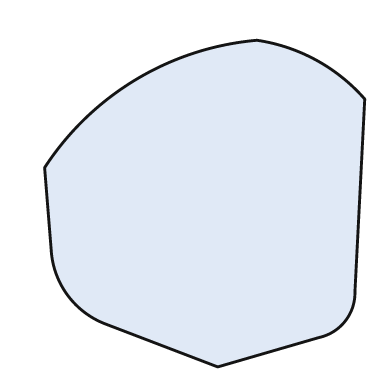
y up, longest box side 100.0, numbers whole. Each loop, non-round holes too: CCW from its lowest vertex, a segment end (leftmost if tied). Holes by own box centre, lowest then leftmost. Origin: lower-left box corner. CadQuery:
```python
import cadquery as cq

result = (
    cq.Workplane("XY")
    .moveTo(53.0, 0.0)
    .lineTo(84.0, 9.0)
    .threePointArc((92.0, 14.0), (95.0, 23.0))
    .lineTo(98.0, 82.0)
    .threePointArc((83.0, 94.0), (65.0, 100.0))
    .threePointArc((28.0, 88.0), (0.0, 61.0))
    .lineTo(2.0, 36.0)
    .threePointArc((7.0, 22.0), (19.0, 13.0))
    .close()
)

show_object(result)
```